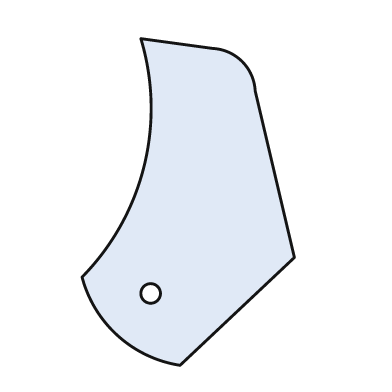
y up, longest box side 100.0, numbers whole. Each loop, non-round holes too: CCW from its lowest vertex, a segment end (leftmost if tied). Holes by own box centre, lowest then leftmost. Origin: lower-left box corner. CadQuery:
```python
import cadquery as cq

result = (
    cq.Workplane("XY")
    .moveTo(30.0, 0.0)
    .lineTo(65.0, 33.0)
    .lineTo(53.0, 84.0)
    .threePointArc((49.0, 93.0), (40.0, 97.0))
    .lineTo(18.0, 100.0)
    .threePointArc((19.0, 61.0), (0.0, 27.0))
    .threePointArc((11.0, 9.0), (30.0, 0.0))
    .close()
    .moveTo(21.0, 22.0)
    .circle(3.0)
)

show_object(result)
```